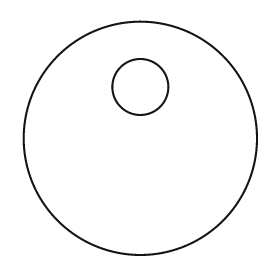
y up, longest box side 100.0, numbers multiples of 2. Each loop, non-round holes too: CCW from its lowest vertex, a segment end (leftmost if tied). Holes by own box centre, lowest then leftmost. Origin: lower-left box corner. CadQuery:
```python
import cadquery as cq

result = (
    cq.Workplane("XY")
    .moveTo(50.0, 50.0)
    .circle(50.0)
    .moveTo(50.0, 72.0)
    .circle(12.0)
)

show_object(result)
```